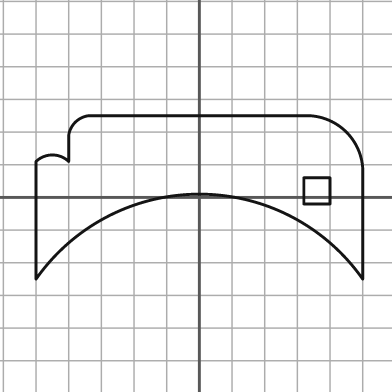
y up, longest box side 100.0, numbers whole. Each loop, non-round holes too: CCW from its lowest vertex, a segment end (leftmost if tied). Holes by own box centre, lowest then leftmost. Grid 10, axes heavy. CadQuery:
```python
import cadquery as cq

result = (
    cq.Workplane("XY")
    .moveTo(-50.0, -25.0)
    .threePointArc((0.0, 1.0), (50.0, -25.0))
    .lineTo(50.0, 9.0)
    .threePointArc((45.0, 20.0), (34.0, 25.0))
    .lineTo(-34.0, 25.0)
    .threePointArc((-38.0, 23.0), (-40.0, 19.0))
    .lineTo(-40.0, 11.0)
    .threePointArc((-45.0, 13.0), (-50.0, 11.0))
    .close()
    .moveTo(32.0, -2.0)
    .lineTo(40.0, -2.0)
    .lineTo(40.0, 6.0)
    .lineTo(32.0, 6.0)
    .close()
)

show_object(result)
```